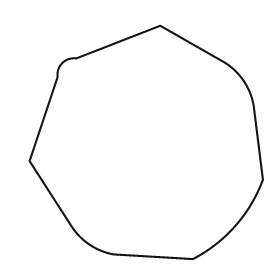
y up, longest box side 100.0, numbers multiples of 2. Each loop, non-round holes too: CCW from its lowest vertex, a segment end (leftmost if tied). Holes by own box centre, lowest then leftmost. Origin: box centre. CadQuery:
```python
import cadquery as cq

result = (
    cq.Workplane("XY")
    .moveTo(20.0, -50.0)
    .threePointArc((38.0, -36.0), (50.0, -16.0))
    .lineTo(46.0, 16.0)
    .threePointArc((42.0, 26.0), (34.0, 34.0))
    .lineTo(6.0, 50.0)
    .lineTo(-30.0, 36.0)
    .threePointArc((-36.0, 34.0), (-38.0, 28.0))
    .lineTo(-50.0, -8.0)
    .lineTo(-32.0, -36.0)
    .threePointArc((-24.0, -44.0), (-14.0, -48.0))
    .close()
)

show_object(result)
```